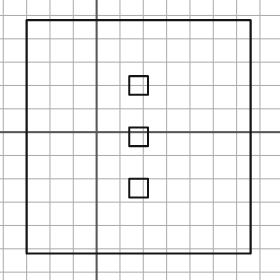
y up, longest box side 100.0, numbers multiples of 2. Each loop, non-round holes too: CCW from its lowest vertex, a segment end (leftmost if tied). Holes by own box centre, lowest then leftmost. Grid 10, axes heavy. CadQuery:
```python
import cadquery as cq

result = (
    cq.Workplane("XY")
    .moveTo(-30.0, -52.0)
    .lineTo(66.0, -52.0)
    .lineTo(66.0, 48.0)
    .lineTo(-30.0, 48.0)
    .close()
    .moveTo(14.0, -28.0)
    .lineTo(22.0, -28.0)
    .lineTo(22.0, -20.0)
    .lineTo(14.0, -20.0)
    .close()
    .moveTo(14.0, -6.0)
    .lineTo(22.0, -6.0)
    .lineTo(22.0, 2.0)
    .lineTo(14.0, 2.0)
    .close()
    .moveTo(14.0, 16.0)
    .lineTo(22.0, 16.0)
    .lineTo(22.0, 24.0)
    .lineTo(14.0, 24.0)
    .close()
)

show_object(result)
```